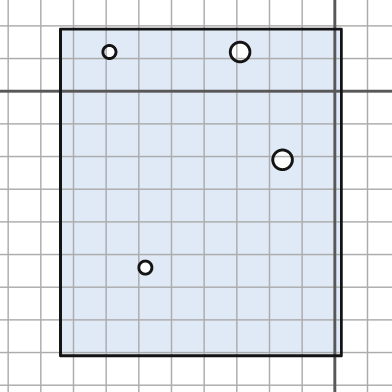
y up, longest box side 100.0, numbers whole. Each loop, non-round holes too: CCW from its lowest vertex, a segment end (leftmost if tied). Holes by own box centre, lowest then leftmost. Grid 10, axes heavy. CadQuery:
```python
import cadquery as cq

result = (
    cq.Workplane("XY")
    .moveTo(-84.0, -81.0)
    .lineTo(2.0, -81.0)
    .lineTo(2.0, 19.0)
    .lineTo(-84.0, 19.0)
    .close()
    .moveTo(-58.0, -54.0)
    .circle(2.0)
    .moveTo(-16.0, -21.0)
    .circle(3.0)
    .moveTo(-69.0, 12.0)
    .circle(2.0)
    .moveTo(-29.0, 12.0)
    .circle(3.0)
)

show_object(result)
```